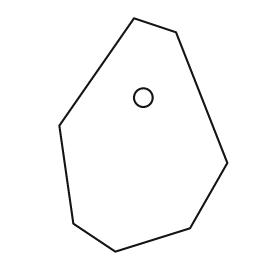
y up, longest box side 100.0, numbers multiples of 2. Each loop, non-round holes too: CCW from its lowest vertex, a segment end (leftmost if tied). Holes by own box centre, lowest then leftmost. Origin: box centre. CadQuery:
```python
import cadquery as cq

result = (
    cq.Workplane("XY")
    .moveTo(-12.0, -50.0)
    .lineTo(20.0, -40.0)
    .lineTo(36.0, -12.0)
    .lineTo(14.0, 44.0)
    .lineTo(-4.0, 50.0)
    .lineTo(-36.0, 4.0)
    .lineTo(-30.0, -38.0)
    .close()
    .moveTo(0.0, 16.0)
    .circle(4.0)
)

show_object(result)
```